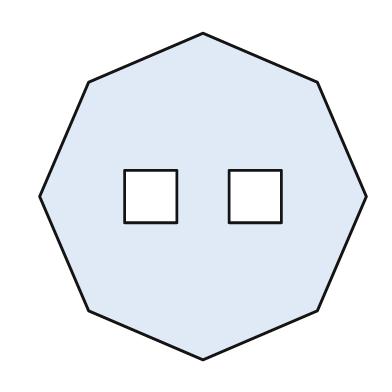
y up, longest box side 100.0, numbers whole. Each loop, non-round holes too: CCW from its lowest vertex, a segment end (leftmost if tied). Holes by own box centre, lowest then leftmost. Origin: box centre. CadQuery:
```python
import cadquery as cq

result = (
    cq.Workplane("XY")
    .moveTo(0.0, -50.0)
    .lineTo(35.0, -35.0)
    .lineTo(50.0, 0.0)
    .lineTo(35.0, 35.0)
    .lineTo(0.0, 50.0)
    .lineTo(-35.0, 35.0)
    .lineTo(-50.0, 0.0)
    .lineTo(-35.0, -35.0)
    .close()
    .moveTo(-24.0, -8.0)
    .lineTo(-8.0, -8.0)
    .lineTo(-8.0, 8.0)
    .lineTo(-24.0, 8.0)
    .close()
    .moveTo(8.0, -8.0)
    .lineTo(24.0, -8.0)
    .lineTo(24.0, 8.0)
    .lineTo(8.0, 8.0)
    .close()
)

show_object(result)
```